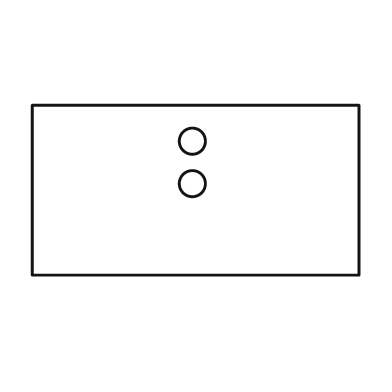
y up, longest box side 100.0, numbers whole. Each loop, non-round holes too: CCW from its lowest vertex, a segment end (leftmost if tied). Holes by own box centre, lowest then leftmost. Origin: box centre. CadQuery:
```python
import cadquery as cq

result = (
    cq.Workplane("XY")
    .moveTo(-50.0, -26.0)
    .lineTo(50.0, -26.0)
    .lineTo(50.0, 26.0)
    .lineTo(-50.0, 26.0)
    .close()
    .moveTo(-1.0, 2.0)
    .circle(4.0)
    .moveTo(-1.0, 15.0)
    .circle(4.0)
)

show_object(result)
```